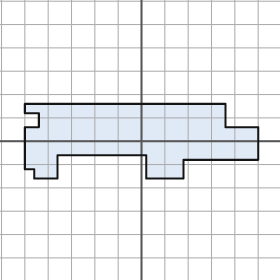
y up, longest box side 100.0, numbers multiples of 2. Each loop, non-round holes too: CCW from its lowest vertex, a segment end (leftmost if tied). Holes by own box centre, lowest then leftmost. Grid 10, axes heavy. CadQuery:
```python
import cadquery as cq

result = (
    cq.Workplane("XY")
    .moveTo(-46.0, -16.0)
    .lineTo(-36.0, -16.0)
    .lineTo(-36.0, -6.0)
    .lineTo(2.0, -6.0)
    .lineTo(2.0, -16.0)
    .lineTo(18.0, -16.0)
    .lineTo(18.0, -8.0)
    .lineTo(50.0, -8.0)
    .lineTo(50.0, 6.0)
    .lineTo(36.0, 6.0)
    .lineTo(36.0, 16.0)
    .lineTo(-50.0, 16.0)
    .lineTo(-50.0, 12.0)
    .lineTo(-44.0, 12.0)
    .lineTo(-44.0, 6.0)
    .lineTo(-50.0, 6.0)
    .lineTo(-50.0, -12.0)
    .lineTo(-46.0, -12.0)
    .close()
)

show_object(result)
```